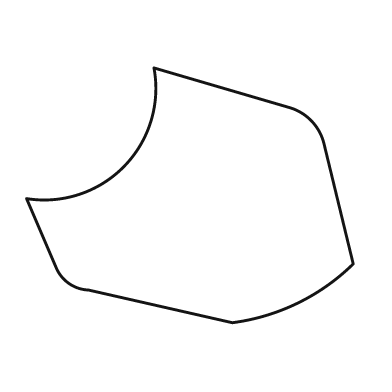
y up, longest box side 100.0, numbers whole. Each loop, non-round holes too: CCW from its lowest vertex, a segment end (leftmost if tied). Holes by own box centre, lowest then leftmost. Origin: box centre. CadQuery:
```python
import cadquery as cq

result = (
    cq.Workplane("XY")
    .moveTo(13.0, -39.0)
    .threePointArc((33.0, -33.0), (50.0, -21.0))
    .lineTo(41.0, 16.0)
    .threePointArc((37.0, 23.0), (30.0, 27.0))
    .lineTo(-11.0, 39.0)
    .threePointArc((-20.0, 9.0), (-50.0, -1.0))
    .lineTo(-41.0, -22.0)
    .threePointArc((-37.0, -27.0), (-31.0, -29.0))
    .close()
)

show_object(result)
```